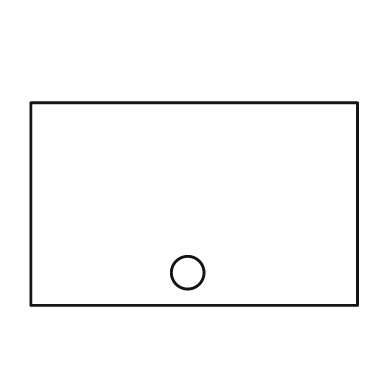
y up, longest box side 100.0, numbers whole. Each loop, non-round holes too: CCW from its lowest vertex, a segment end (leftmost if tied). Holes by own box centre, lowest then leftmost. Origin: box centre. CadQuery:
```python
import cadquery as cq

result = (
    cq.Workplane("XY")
    .moveTo(-50.0, -31.0)
    .lineTo(50.0, -31.0)
    .lineTo(50.0, 31.0)
    .lineTo(-50.0, 31.0)
    .close()
    .moveTo(-2.0, -21.0)
    .circle(5.0)
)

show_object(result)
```